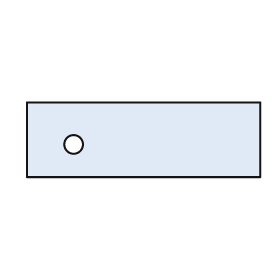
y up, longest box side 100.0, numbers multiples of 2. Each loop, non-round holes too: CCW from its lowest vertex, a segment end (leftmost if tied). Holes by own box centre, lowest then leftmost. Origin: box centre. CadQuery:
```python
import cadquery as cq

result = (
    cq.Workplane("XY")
    .moveTo(-50.0, -16.0)
    .lineTo(50.0, -16.0)
    .lineTo(50.0, 16.0)
    .lineTo(-50.0, 16.0)
    .close()
    .moveTo(-30.0, -2.0)
    .circle(4.0)
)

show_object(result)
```